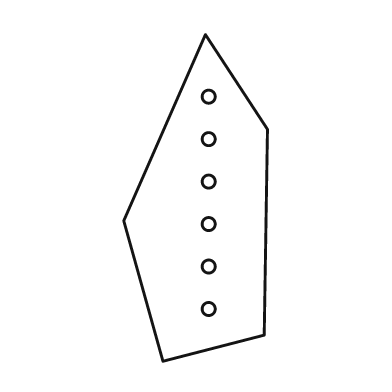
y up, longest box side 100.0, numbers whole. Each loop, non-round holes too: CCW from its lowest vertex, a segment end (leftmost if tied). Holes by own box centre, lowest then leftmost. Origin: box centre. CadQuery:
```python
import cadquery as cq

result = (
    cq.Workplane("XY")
    .moveTo(-10.0, -50.0)
    .lineTo(21.0, -42.0)
    .lineTo(22.0, 21.0)
    .lineTo(3.0, 50.0)
    .lineTo(-22.0, -7.0)
    .close()
    .moveTo(4.0, -34.0)
    .circle(2.0)
    .moveTo(4.0, -21.0)
    .circle(2.0)
    .moveTo(4.0, -8.0)
    .circle(2.0)
    .moveTo(4.0, 5.0)
    .circle(2.0)
    .moveTo(4.0, 18.0)
    .circle(2.0)
    .moveTo(4.0, 31.0)
    .circle(2.0)
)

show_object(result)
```